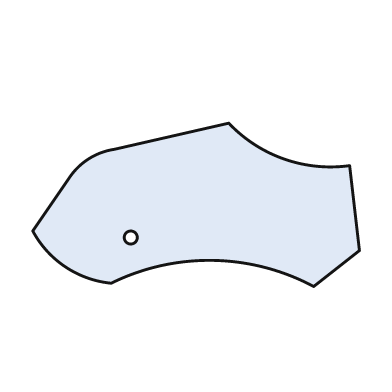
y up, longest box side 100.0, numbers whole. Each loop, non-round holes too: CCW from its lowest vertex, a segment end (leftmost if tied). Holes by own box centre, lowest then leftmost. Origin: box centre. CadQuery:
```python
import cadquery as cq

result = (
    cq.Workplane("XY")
    .moveTo(36.0, -25.0)
    .lineTo(50.0, -14.0)
    .lineTo(47.0, 12.0)
    .threePointArc((27.0, 14.0), (10.0, 25.0))
    .lineTo(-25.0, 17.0)
    .threePointArc((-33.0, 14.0), (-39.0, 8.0))
    .lineTo(-50.0, -8.0)
    .threePointArc((-40.0, -19.0), (-26.0, -24.0))
    .threePointArc((5.0, -17.0), (36.0, -25.0))
    .close()
    .moveTo(-20.0, -10.0)
    .circle(2.0)
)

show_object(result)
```